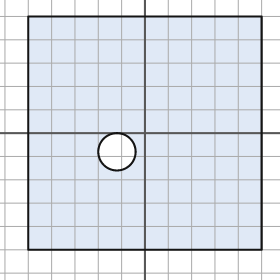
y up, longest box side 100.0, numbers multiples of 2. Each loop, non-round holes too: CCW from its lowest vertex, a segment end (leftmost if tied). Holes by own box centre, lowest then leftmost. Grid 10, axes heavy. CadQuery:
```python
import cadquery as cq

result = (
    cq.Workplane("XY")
    .moveTo(-50.0, -50.0)
    .lineTo(50.0, -50.0)
    .lineTo(50.0, 50.0)
    .lineTo(-50.0, 50.0)
    .close()
    .moveTo(-12.0, -8.0)
    .circle(8.0)
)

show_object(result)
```